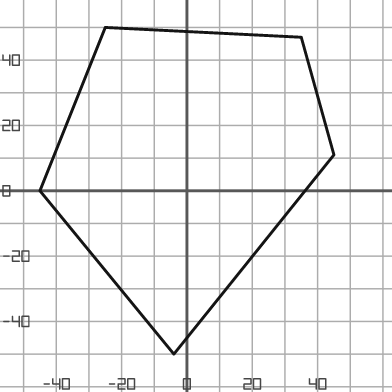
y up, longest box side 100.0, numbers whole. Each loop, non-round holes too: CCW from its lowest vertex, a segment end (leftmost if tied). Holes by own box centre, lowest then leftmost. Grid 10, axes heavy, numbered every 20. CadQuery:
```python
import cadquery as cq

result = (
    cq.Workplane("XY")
    .moveTo(-4.0, -50.0)
    .lineTo(45.0, 11.0)
    .lineTo(35.0, 47.0)
    .lineTo(-25.0, 50.0)
    .lineTo(-45.0, 0.0)
    .close()
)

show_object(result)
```